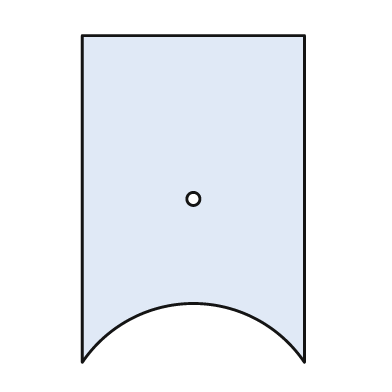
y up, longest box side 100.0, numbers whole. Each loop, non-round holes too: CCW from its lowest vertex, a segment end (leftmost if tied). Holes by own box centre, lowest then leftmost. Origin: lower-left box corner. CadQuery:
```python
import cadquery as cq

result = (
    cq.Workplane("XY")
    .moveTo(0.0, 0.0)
    .threePointArc((34.0, 18.0), (68.0, 0.0))
    .lineTo(68.0, 100.0)
    .lineTo(0.0, 100.0)
    .close()
    .moveTo(34.0, 50.0)
    .circle(2.0)
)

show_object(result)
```